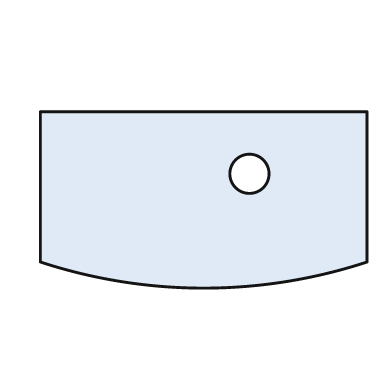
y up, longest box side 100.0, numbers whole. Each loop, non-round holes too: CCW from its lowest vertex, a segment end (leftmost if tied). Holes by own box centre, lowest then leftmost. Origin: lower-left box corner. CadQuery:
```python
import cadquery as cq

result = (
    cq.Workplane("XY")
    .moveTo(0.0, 8.0)
    .threePointArc((50.0, 0.0), (100.0, 8.0))
    .lineTo(100.0, 54.0)
    .lineTo(0.0, 54.0)
    .close()
    .moveTo(64.0, 35.0)
    .circle(6.0)
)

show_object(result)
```